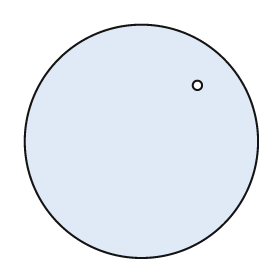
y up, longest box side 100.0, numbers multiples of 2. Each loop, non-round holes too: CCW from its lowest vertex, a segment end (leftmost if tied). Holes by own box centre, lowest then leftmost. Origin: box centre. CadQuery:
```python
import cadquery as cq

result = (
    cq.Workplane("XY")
    .moveTo(0.0, 0.0)
    .circle(50.0)
    .moveTo(24.0, 24.0)
    .circle(2.0)
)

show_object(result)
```